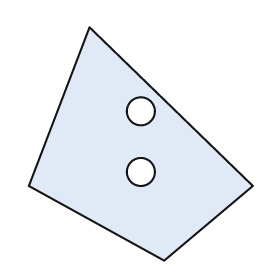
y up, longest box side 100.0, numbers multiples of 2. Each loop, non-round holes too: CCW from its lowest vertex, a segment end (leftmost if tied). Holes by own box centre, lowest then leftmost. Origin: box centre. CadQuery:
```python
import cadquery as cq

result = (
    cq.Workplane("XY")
    .moveTo(10.0, -50.0)
    .lineTo(48.0, -18.0)
    .lineTo(-22.0, 50.0)
    .lineTo(-48.0, -18.0)
    .close()
    .moveTo(0.0, -12.0)
    .circle(6.0)
    .moveTo(0.0, 14.0)
    .circle(6.0)
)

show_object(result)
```